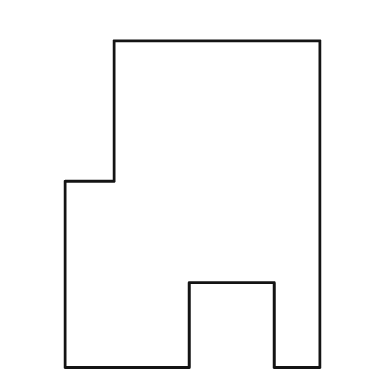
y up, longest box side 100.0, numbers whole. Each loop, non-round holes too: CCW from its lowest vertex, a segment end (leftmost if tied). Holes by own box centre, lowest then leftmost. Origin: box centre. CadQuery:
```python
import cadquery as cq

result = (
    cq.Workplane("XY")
    .moveTo(-39.0, -50.0)
    .lineTo(-1.0, -50.0)
    .lineTo(-1.0, -24.0)
    .lineTo(25.0, -24.0)
    .lineTo(25.0, -50.0)
    .lineTo(39.0, -50.0)
    .lineTo(39.0, 50.0)
    .lineTo(-24.0, 50.0)
    .lineTo(-24.0, 7.0)
    .lineTo(-39.0, 7.0)
    .close()
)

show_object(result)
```